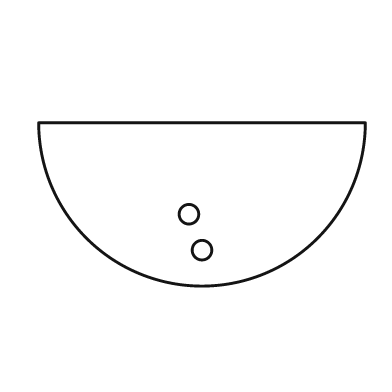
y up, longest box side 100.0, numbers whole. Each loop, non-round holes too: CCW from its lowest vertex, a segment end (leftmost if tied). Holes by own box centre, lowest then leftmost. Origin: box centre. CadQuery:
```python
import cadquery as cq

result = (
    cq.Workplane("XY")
    .moveTo(-50.0, 25.0)
    .threePointArc((0.0, -25.0), (50.0, 25.0))
    .close()
    .moveTo(0.0, -14.0)
    .circle(3.0)
    .moveTo(-4.0, -3.0)
    .circle(3.0)
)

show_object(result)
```